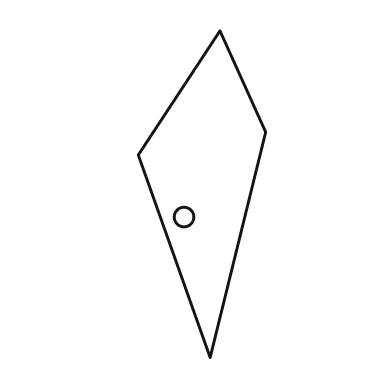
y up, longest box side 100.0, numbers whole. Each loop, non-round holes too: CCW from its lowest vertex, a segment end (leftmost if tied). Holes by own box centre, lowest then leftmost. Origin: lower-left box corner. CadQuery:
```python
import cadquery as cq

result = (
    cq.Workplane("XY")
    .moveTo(22.0, 0.0)
    .lineTo(39.0, 69.0)
    .lineTo(25.0, 100.0)
    .lineTo(0.0, 62.0)
    .close()
    .moveTo(14.0, 43.0)
    .circle(3.0)
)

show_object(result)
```